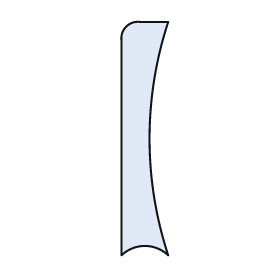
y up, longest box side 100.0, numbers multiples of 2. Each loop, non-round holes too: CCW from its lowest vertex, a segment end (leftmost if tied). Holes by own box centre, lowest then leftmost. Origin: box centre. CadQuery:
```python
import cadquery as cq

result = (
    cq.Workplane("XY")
    .moveTo(-10.0, -50.0)
    .threePointArc((0.0, -46.0), (10.0, -50.0))
    .threePointArc((2.0, 0.0), (10.0, 50.0))
    .lineTo(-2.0, 50.0)
    .threePointArc((-8.0, 48.0), (-10.0, 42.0))
    .close()
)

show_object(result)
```